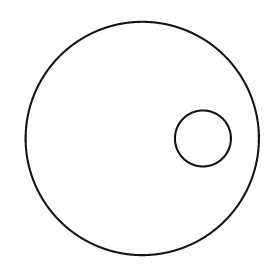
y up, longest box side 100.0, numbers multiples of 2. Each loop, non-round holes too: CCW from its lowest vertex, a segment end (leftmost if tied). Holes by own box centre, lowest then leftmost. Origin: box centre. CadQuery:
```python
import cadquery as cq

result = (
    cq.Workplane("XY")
    .moveTo(0.0, 0.0)
    .circle(50.0)
    .moveTo(26.0, 0.0)
    .circle(12.0)
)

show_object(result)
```